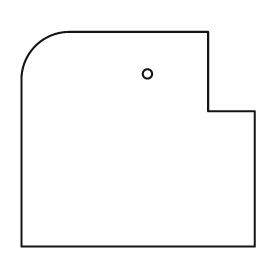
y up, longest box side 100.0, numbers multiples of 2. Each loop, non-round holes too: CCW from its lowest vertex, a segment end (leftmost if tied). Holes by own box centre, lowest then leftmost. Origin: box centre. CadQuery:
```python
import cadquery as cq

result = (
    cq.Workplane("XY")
    .moveTo(-50.0, -46.0)
    .lineTo(50.0, -46.0)
    .lineTo(50.0, 12.0)
    .lineTo(30.0, 12.0)
    .lineTo(30.0, 46.0)
    .lineTo(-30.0, 46.0)
    .threePointArc((-44.0, 40.0), (-50.0, 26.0))
    .close()
    .moveTo(4.0, 28.0)
    .circle(2.0)
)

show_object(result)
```